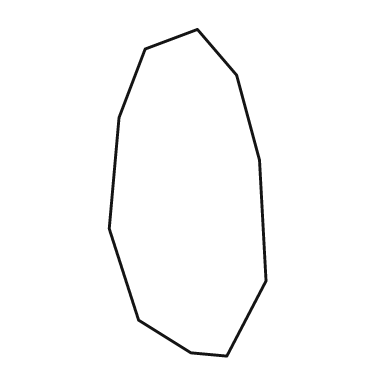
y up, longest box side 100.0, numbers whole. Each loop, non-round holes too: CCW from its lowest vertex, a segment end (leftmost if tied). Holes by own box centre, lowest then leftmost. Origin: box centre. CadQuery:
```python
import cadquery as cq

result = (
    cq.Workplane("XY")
    .moveTo(12.0, -50.0)
    .lineTo(24.0, -27.0)
    .lineTo(22.0, 10.0)
    .lineTo(15.0, 36.0)
    .lineTo(3.0, 50.0)
    .lineTo(-13.0, 44.0)
    .lineTo(-21.0, 23.0)
    .lineTo(-24.0, -11.0)
    .lineTo(-15.0, -39.0)
    .lineTo(1.0, -49.0)
    .close()
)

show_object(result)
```